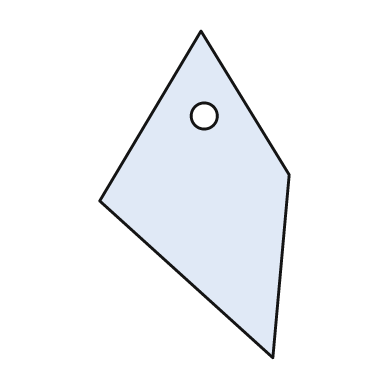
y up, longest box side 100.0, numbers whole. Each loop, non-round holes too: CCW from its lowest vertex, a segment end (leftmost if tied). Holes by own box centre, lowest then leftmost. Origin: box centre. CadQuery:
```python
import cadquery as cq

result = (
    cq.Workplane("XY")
    .moveTo(24.0, -50.0)
    .lineTo(29.0, 6.0)
    .lineTo(2.0, 50.0)
    .lineTo(-29.0, -2.0)
    .close()
    .moveTo(3.0, 24.0)
    .circle(4.0)
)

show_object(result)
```